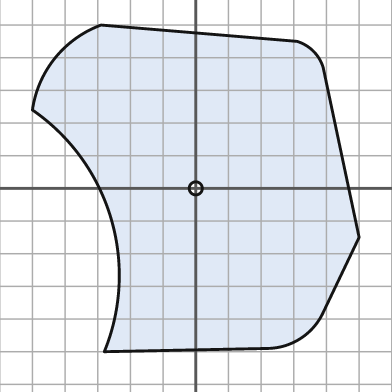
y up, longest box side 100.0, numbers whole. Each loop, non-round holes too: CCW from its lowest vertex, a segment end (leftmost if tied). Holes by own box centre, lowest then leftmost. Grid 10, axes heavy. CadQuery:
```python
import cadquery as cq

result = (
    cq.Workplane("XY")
    .moveTo(-28.0, -50.0)
    .lineTo(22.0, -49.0)
    .threePointArc((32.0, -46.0), (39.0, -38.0))
    .lineTo(50.0, -15.0)
    .lineTo(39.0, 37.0)
    .threePointArc((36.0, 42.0), (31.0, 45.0))
    .lineTo(-29.0, 50.0)
    .threePointArc((-43.0, 40.0), (-50.0, 24.0))
    .threePointArc((-26.0, -9.0), (-28.0, -50.0))
    .close()
    .moveTo(0.0, 0.0)
    .circle(2.0)
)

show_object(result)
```